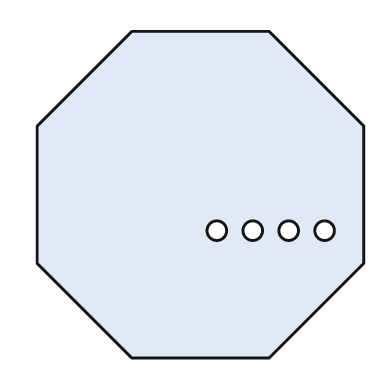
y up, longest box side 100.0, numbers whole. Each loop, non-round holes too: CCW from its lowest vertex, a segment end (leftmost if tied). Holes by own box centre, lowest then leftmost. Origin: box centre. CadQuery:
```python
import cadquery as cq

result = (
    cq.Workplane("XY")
    .moveTo(-21.0, -50.0)
    .lineTo(21.0, -50.0)
    .lineTo(50.0, -21.0)
    .lineTo(50.0, 21.0)
    .lineTo(21.0, 50.0)
    .lineTo(-21.0, 50.0)
    .lineTo(-50.0, 21.0)
    .lineTo(-50.0, -21.0)
    .close()
    .moveTo(5.0, -11.0)
    .circle(3.0)
    .moveTo(16.0, -11.0)
    .circle(3.0)
    .moveTo(27.0, -11.0)
    .circle(3.0)
    .moveTo(38.0, -11.0)
    .circle(3.0)
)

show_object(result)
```